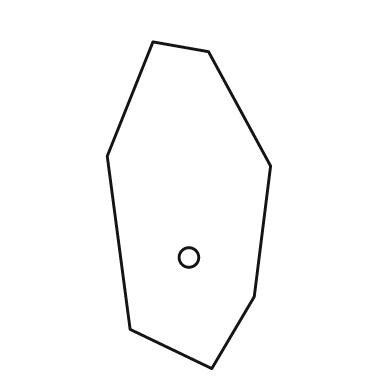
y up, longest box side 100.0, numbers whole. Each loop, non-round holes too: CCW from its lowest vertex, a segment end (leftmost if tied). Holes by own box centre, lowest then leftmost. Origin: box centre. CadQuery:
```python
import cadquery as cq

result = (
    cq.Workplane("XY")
    .moveTo(7.0, -50.0)
    .lineTo(20.0, -28.0)
    .lineTo(25.0, 12.0)
    .lineTo(6.0, 47.0)
    .lineTo(-11.0, 50.0)
    .lineTo(-25.0, 15.0)
    .lineTo(-18.0, -38.0)
    .close()
    .moveTo(0.0, -16.0)
    .circle(3.0)
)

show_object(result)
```